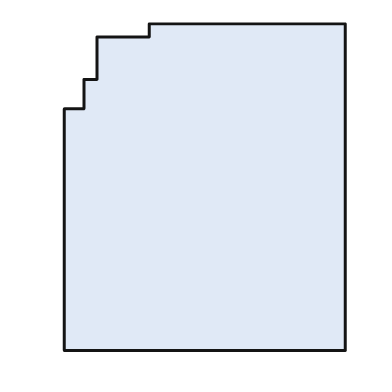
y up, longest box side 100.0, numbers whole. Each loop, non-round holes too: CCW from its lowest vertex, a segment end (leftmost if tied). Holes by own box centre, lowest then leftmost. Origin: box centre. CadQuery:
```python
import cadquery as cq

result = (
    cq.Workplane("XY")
    .moveTo(-43.0, -50.0)
    .lineTo(43.0, -50.0)
    .lineTo(43.0, 50.0)
    .lineTo(-17.0, 50.0)
    .lineTo(-17.0, 46.0)
    .lineTo(-33.0, 46.0)
    .lineTo(-33.0, 33.0)
    .lineTo(-37.0, 33.0)
    .lineTo(-37.0, 24.0)
    .lineTo(-43.0, 24.0)
    .close()
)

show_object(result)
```